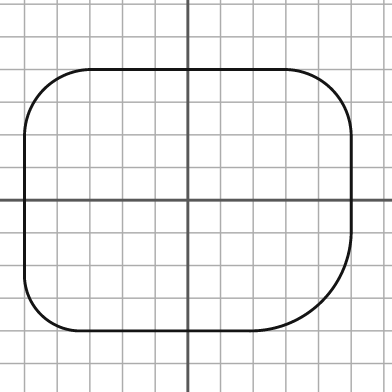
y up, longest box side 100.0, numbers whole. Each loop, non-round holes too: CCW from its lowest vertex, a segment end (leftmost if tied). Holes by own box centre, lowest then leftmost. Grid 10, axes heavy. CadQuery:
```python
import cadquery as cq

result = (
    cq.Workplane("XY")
    .moveTo(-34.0, -40.0)
    .lineTo(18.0, -40.0)
    .threePointArc((41.0, -31.0), (50.0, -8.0))
    .lineTo(50.0, 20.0)
    .threePointArc((44.0, 34.0), (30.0, 40.0))
    .lineTo(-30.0, 40.0)
    .threePointArc((-44.0, 34.0), (-50.0, 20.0))
    .lineTo(-50.0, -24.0)
    .threePointArc((-45.0, -35.0), (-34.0, -40.0))
    .close()
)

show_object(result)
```